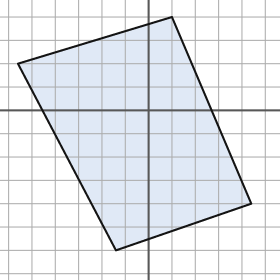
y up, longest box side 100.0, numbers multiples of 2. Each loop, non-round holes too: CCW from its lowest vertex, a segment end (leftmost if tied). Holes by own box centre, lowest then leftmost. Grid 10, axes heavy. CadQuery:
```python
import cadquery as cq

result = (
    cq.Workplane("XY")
    .moveTo(-14.0, -60.0)
    .lineTo(44.0, -40.0)
    .lineTo(10.0, 40.0)
    .lineTo(-56.0, 20.0)
    .close()
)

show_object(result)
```